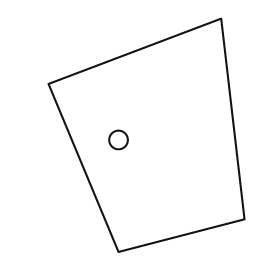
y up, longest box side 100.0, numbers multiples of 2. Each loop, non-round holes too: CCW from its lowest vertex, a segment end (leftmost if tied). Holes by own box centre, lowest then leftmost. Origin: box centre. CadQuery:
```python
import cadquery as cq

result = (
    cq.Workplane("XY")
    .moveTo(-12.0, -50.0)
    .lineTo(42.0, -36.0)
    .lineTo(32.0, 50.0)
    .lineTo(-42.0, 22.0)
    .close()
    .moveTo(-12.0, -2.0)
    .circle(4.0)
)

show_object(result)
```